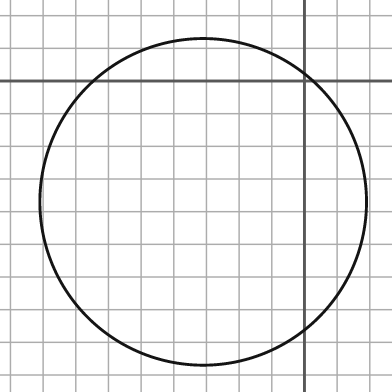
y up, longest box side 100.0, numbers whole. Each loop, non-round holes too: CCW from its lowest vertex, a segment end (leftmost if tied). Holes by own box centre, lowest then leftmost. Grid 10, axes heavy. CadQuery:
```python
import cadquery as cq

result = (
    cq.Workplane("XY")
    .moveTo(-31.0, -37.0)
    .circle(50.0)
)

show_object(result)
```